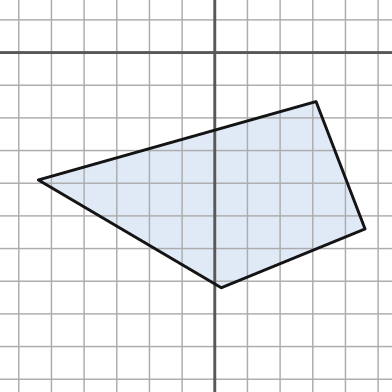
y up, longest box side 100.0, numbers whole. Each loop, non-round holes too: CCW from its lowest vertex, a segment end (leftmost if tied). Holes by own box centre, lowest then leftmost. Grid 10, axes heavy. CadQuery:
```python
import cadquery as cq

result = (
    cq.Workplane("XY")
    .moveTo(2.0, -72.0)
    .lineTo(46.0, -54.0)
    .lineTo(31.0, -15.0)
    .lineTo(-54.0, -39.0)
    .close()
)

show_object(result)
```